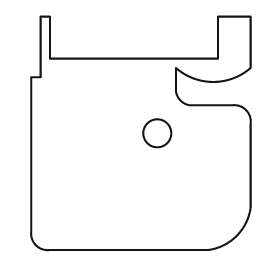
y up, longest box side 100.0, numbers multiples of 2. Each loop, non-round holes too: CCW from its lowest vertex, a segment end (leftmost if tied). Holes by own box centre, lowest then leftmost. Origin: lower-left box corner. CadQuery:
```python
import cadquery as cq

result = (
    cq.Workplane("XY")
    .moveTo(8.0, 0.0)
    .lineTo(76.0, 0.0)
    .threePointArc((88.0, 6.0), (94.0, 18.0))
    .lineTo(94.0, 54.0)
    .threePointArc((92.0, 60.0), (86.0, 62.0))
    .lineTo(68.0, 62.0)
    .threePointArc((64.0, 64.0), (62.0, 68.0))
    .lineTo(62.0, 78.0)
    .threePointArc((78.0, 72.0), (94.0, 78.0))
    .lineTo(94.0, 100.0)
    .lineTo(80.0, 100.0)
    .lineTo(80.0, 82.0)
    .lineTo(8.0, 82.0)
    .lineTo(8.0, 100.0)
    .lineTo(4.0, 100.0)
    .lineTo(4.0, 74.0)
    .lineTo(0.0, 74.0)
    .lineTo(0.0, 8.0)
    .threePointArc((2.0, 2.0), (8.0, 0.0))
    .close()
    .moveTo(54.0, 50.0)
    .circle(6.0)
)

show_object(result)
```